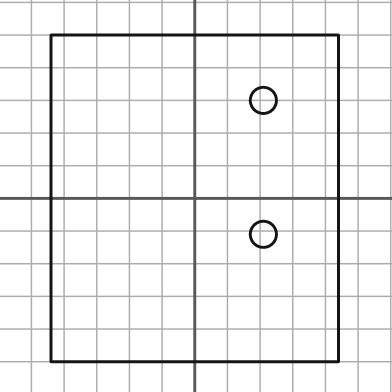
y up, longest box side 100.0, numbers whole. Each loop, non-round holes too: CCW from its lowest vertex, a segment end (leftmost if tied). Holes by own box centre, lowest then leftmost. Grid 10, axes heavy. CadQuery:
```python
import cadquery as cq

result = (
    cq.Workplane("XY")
    .moveTo(-44.0, -50.0)
    .lineTo(44.0, -50.0)
    .lineTo(44.0, 50.0)
    .lineTo(-44.0, 50.0)
    .close()
    .moveTo(21.0, -11.0)
    .circle(4.0)
    .moveTo(21.0, 30.0)
    .circle(4.0)
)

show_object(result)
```